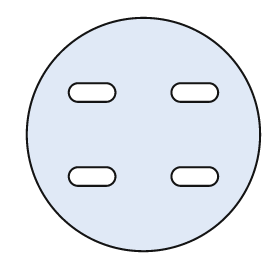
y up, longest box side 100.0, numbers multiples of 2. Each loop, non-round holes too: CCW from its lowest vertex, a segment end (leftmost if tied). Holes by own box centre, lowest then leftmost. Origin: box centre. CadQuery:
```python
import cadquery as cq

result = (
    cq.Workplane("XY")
    .moveTo(0.0, 0.0)
    .circle(50.0)
    .moveTo(-28.0, -22.0)
    .lineTo(-16.0, -22.0)
    .threePointArc((-12.0, -18.0), (-16.0, -14.0))
    .lineTo(-28.0, -14.0)
    .threePointArc((-32.0, -18.0), (-28.0, -22.0))
    .close()
    .moveTo(16.0, -22.0)
    .lineTo(28.0, -22.0)
    .threePointArc((32.0, -18.0), (28.0, -14.0))
    .lineTo(16.0, -14.0)
    .threePointArc((12.0, -18.0), (16.0, -22.0))
    .close()
    .moveTo(-28.0, 14.0)
    .lineTo(-16.0, 14.0)
    .threePointArc((-12.0, 18.0), (-16.0, 22.0))
    .lineTo(-28.0, 22.0)
    .threePointArc((-32.0, 18.0), (-28.0, 14.0))
    .close()
    .moveTo(16.0, 14.0)
    .lineTo(28.0, 14.0)
    .threePointArc((32.0, 18.0), (28.0, 22.0))
    .lineTo(16.0, 22.0)
    .threePointArc((12.0, 18.0), (16.0, 14.0))
    .close()
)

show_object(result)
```